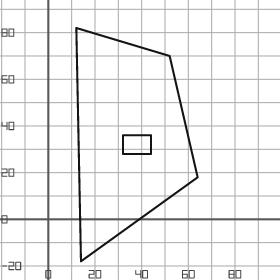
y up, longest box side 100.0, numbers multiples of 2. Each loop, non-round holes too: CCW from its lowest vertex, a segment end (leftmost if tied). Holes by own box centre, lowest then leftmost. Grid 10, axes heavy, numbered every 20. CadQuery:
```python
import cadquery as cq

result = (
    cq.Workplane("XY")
    .moveTo(14.0, -18.0)
    .lineTo(64.0, 18.0)
    .lineTo(52.0, 70.0)
    .lineTo(12.0, 82.0)
    .close()
    .moveTo(32.0, 28.0)
    .lineTo(44.0, 28.0)
    .lineTo(44.0, 36.0)
    .lineTo(32.0, 36.0)
    .close()
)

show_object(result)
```